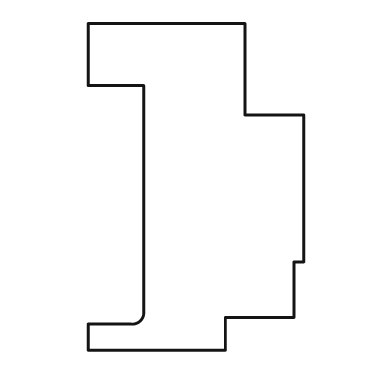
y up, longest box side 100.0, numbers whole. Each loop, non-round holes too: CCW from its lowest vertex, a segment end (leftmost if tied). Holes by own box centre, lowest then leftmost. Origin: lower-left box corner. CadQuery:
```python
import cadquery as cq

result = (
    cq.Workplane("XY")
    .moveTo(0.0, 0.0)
    .lineTo(42.0, 0.0)
    .lineTo(42.0, 10.0)
    .lineTo(63.0, 10.0)
    .lineTo(63.0, 27.0)
    .lineTo(66.0, 27.0)
    .lineTo(66.0, 72.0)
    .lineTo(48.0, 72.0)
    .lineTo(48.0, 100.0)
    .lineTo(0.0, 100.0)
    .lineTo(0.0, 81.0)
    .lineTo(17.0, 81.0)
    .lineTo(17.0, 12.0)
    .threePointArc((16.0, 9.0), (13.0, 8.0))
    .lineTo(0.0, 8.0)
    .close()
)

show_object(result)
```